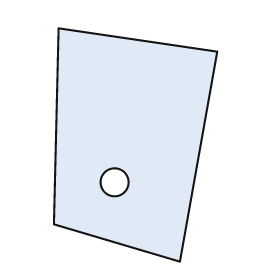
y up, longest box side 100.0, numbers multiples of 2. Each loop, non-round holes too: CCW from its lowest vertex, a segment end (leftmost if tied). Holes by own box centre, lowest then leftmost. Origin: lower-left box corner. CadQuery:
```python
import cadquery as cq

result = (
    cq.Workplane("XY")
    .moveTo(54.0, 0.0)
    .lineTo(70.0, 90.0)
    .lineTo(2.0, 100.0)
    .lineTo(0.0, 16.0)
    .close()
    .moveTo(26.0, 34.0)
    .circle(6.0)
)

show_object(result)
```